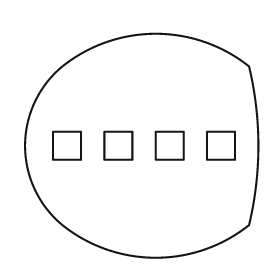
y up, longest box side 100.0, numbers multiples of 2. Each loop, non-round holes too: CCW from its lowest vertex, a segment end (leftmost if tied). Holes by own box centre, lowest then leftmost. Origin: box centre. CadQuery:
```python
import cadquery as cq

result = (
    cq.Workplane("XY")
    .moveTo(-34.0, -34.0)
    .threePointArc((6.0, -48.0), (46.0, -34.0))
    .threePointArc((50.0, 0.0), (46.0, 34.0))
    .threePointArc((6.0, 48.0), (-34.0, 34.0))
    .threePointArc((-50.0, 0.0), (-34.0, -34.0))
    .close()
    .moveTo(-38.0, -6.0)
    .lineTo(-26.0, -6.0)
    .lineTo(-26.0, 6.0)
    .lineTo(-38.0, 6.0)
    .close()
    .moveTo(-16.0, -6.0)
    .lineTo(-4.0, -6.0)
    .lineTo(-4.0, 6.0)
    .lineTo(-16.0, 6.0)
    .close()
    .moveTo(6.0, -6.0)
    .lineTo(18.0, -6.0)
    .lineTo(18.0, 6.0)
    .lineTo(6.0, 6.0)
    .close()
    .moveTo(28.0, -6.0)
    .lineTo(40.0, -6.0)
    .lineTo(40.0, 6.0)
    .lineTo(28.0, 6.0)
    .close()
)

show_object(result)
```